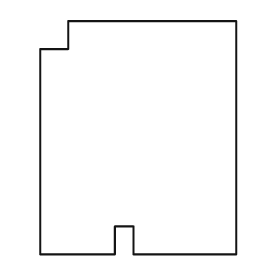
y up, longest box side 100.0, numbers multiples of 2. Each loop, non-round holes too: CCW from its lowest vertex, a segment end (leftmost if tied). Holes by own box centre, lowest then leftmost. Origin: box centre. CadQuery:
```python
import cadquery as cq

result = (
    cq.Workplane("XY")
    .moveTo(-42.0, -50.0)
    .lineTo(-10.0, -50.0)
    .lineTo(-10.0, -38.0)
    .lineTo(-2.0, -38.0)
    .lineTo(-2.0, -50.0)
    .lineTo(42.0, -50.0)
    .lineTo(42.0, 50.0)
    .lineTo(-30.0, 50.0)
    .lineTo(-30.0, 38.0)
    .lineTo(-42.0, 38.0)
    .close()
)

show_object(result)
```